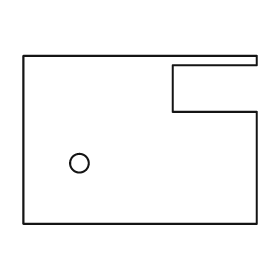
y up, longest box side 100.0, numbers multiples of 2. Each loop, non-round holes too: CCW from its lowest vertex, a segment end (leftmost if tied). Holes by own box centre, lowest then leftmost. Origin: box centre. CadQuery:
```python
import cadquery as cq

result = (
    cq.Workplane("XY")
    .moveTo(-50.0, -36.0)
    .lineTo(50.0, -36.0)
    .lineTo(50.0, 12.0)
    .lineTo(14.0, 12.0)
    .lineTo(14.0, 32.0)
    .lineTo(50.0, 32.0)
    .lineTo(50.0, 36.0)
    .lineTo(-50.0, 36.0)
    .close()
    .moveTo(-26.0, -10.0)
    .circle(4.0)
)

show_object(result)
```